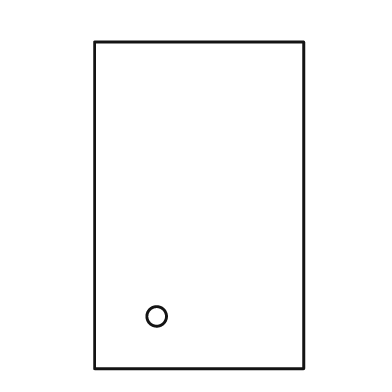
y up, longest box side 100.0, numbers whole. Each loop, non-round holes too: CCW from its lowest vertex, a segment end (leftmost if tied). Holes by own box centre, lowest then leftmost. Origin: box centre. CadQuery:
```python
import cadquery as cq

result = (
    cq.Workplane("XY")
    .moveTo(-32.0, -50.0)
    .lineTo(32.0, -50.0)
    .lineTo(32.0, 50.0)
    .lineTo(-32.0, 50.0)
    .close()
    .moveTo(-13.0, -34.0)
    .circle(3.0)
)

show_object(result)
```